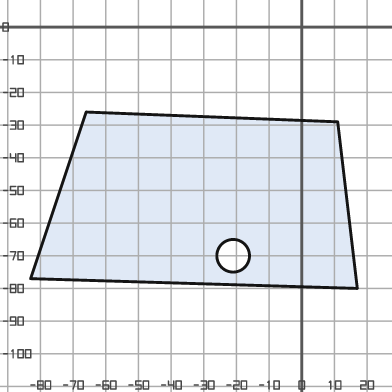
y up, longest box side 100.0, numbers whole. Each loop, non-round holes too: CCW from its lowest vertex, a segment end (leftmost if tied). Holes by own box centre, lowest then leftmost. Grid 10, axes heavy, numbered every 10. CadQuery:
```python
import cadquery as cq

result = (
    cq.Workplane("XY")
    .moveTo(17.0, -80.0)
    .lineTo(11.0, -29.0)
    .lineTo(-66.0, -26.0)
    .lineTo(-83.0, -77.0)
    .close()
    .moveTo(-21.0, -70.0)
    .circle(5.0)
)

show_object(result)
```